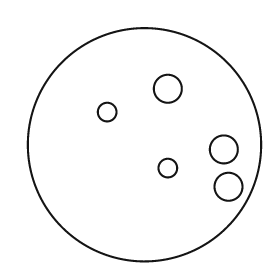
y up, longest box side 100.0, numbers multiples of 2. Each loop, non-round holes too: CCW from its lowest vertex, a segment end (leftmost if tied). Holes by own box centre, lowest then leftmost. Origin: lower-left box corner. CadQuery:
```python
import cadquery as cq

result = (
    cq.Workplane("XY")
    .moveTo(50.0, 50.0)
    .circle(50.0)
    .moveTo(86.0, 32.0)
    .circle(6.0)
    .moveTo(60.0, 40.0)
    .circle(4.0)
    .moveTo(84.0, 48.0)
    .circle(6.0)
    .moveTo(34.0, 64.0)
    .circle(4.0)
    .moveTo(60.0, 74.0)
    .circle(6.0)
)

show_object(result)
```